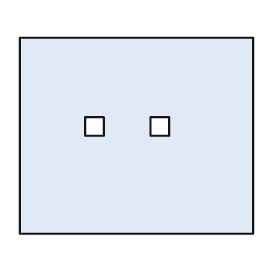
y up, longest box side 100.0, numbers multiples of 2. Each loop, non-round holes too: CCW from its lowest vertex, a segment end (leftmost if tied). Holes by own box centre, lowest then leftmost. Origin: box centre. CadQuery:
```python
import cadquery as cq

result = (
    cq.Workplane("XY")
    .moveTo(-50.0, -42.0)
    .lineTo(50.0, -42.0)
    .lineTo(50.0, 42.0)
    .lineTo(-50.0, 42.0)
    .close()
    .moveTo(-22.0, 0.0)
    .lineTo(-14.0, 0.0)
    .lineTo(-14.0, 8.0)
    .lineTo(-22.0, 8.0)
    .close()
    .moveTo(6.0, 0.0)
    .lineTo(14.0, 0.0)
    .lineTo(14.0, 8.0)
    .lineTo(6.0, 8.0)
    .close()
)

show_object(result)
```